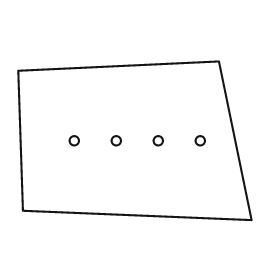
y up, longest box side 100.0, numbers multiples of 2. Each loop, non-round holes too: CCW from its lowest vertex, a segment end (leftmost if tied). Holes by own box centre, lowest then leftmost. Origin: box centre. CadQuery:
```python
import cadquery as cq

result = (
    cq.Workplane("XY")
    .moveTo(50.0, -34.0)
    .lineTo(36.0, 34.0)
    .lineTo(-50.0, 30.0)
    .lineTo(-48.0, -30.0)
    .close()
    .moveTo(-26.0, 0.0)
    .circle(2.0)
    .moveTo(-8.0, 0.0)
    .circle(2.0)
    .moveTo(10.0, 0.0)
    .circle(2.0)
    .moveTo(28.0, 0.0)
    .circle(2.0)
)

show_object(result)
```